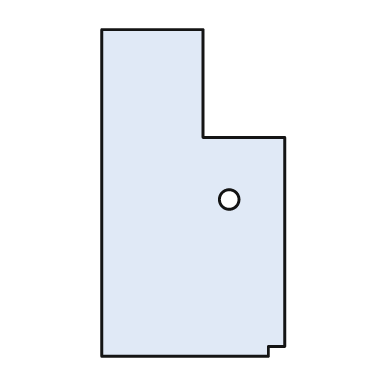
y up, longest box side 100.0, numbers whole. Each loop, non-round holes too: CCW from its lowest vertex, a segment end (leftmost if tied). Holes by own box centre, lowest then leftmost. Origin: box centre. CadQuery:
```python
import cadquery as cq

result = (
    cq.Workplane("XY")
    .moveTo(-28.0, -50.0)
    .lineTo(23.0, -50.0)
    .lineTo(23.0, -47.0)
    .lineTo(28.0, -47.0)
    .lineTo(28.0, 17.0)
    .lineTo(3.0, 17.0)
    .lineTo(3.0, 50.0)
    .lineTo(-28.0, 50.0)
    .close()
    .moveTo(11.0, -2.0)
    .circle(3.0)
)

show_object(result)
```